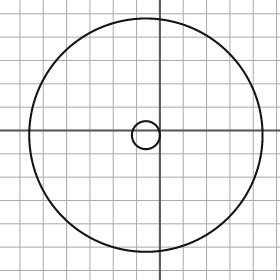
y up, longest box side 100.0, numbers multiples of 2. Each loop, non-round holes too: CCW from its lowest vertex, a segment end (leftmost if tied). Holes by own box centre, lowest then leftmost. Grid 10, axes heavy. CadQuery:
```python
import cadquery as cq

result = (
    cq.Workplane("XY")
    .moveTo(-6.0, -2.0)
    .circle(50.0)
    .moveTo(-6.0, -2.0)
    .circle(6.0)
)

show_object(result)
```